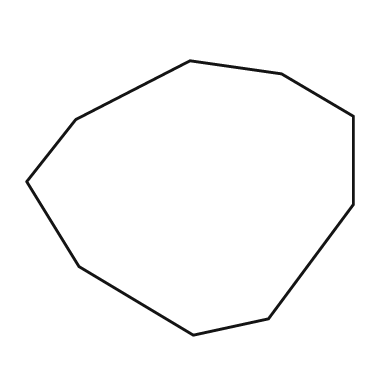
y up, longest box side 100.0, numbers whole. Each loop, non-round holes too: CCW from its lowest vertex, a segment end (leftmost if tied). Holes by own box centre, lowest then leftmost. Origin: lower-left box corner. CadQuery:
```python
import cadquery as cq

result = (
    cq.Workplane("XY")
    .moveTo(51.0, 0.0)
    .lineTo(74.0, 5.0)
    .lineTo(100.0, 40.0)
    .lineTo(100.0, 67.0)
    .lineTo(78.0, 80.0)
    .lineTo(50.0, 84.0)
    .lineTo(15.0, 66.0)
    .lineTo(0.0, 47.0)
    .lineTo(16.0, 21.0)
    .close()
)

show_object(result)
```